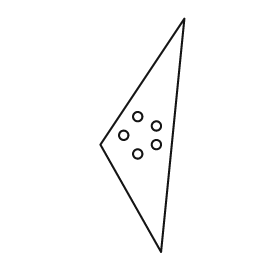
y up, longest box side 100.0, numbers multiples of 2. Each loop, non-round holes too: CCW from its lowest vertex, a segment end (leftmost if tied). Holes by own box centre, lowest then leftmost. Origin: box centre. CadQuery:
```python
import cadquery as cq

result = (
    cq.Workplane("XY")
    .moveTo(8.0, -50.0)
    .lineTo(18.0, 50.0)
    .lineTo(-18.0, -4.0)
    .close()
    .moveTo(-2.0, -8.0)
    .circle(2.0)
    .moveTo(6.0, -4.0)
    .circle(2.0)
    .moveTo(-8.0, 0.0)
    .circle(2.0)
    .moveTo(6.0, 4.0)
    .circle(2.0)
    .moveTo(-2.0, 8.0)
    .circle(2.0)
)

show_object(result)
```